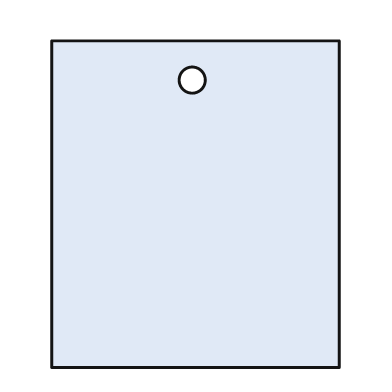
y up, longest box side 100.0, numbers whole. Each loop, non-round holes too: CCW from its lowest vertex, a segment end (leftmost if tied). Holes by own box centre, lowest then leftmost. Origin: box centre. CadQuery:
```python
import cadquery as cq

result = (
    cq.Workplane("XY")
    .moveTo(-44.0, -50.0)
    .lineTo(44.0, -50.0)
    .lineTo(44.0, 50.0)
    .lineTo(-44.0, 50.0)
    .close()
    .moveTo(-1.0, 38.0)
    .circle(4.0)
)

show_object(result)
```